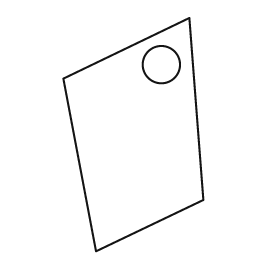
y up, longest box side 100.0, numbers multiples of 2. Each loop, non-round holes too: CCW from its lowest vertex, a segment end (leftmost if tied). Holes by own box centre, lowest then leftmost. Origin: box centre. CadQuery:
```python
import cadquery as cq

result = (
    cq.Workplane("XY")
    .moveTo(-16.0, -50.0)
    .lineTo(30.0, -28.0)
    .lineTo(24.0, 50.0)
    .lineTo(-30.0, 24.0)
    .close()
    .moveTo(12.0, 30.0)
    .circle(8.0)
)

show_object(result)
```